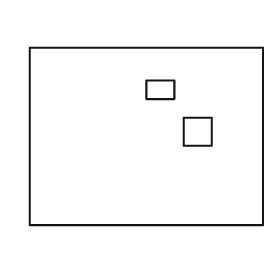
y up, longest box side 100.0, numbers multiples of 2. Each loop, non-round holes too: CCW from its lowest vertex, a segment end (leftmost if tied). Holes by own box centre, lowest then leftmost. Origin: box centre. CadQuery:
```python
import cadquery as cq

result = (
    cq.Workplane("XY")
    .moveTo(-50.0, -38.0)
    .lineTo(50.0, -38.0)
    .lineTo(50.0, 38.0)
    .lineTo(-50.0, 38.0)
    .close()
    .moveTo(16.0, -4.0)
    .lineTo(28.0, -4.0)
    .lineTo(28.0, 8.0)
    .lineTo(16.0, 8.0)
    .close()
    .moveTo(0.0, 16.0)
    .lineTo(12.0, 16.0)
    .lineTo(12.0, 24.0)
    .lineTo(0.0, 24.0)
    .close()
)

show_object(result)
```